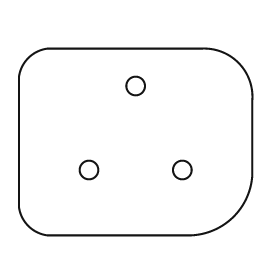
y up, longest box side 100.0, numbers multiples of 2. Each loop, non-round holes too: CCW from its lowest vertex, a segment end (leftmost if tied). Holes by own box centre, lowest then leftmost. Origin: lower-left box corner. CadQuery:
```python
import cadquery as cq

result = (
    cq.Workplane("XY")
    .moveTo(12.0, 0.0)
    .lineTo(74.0, 0.0)
    .threePointArc((92.0, 8.0), (100.0, 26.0))
    .lineTo(100.0, 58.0)
    .threePointArc((94.0, 74.0), (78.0, 80.0))
    .lineTo(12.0, 80.0)
    .threePointArc((4.0, 76.0), (0.0, 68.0))
    .lineTo(0.0, 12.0)
    .threePointArc((4.0, 4.0), (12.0, 0.0))
    .close()
    .moveTo(30.0, 28.0)
    .circle(4.0)
    .moveTo(70.0, 28.0)
    .circle(4.0)
    .moveTo(50.0, 64.0)
    .circle(4.0)
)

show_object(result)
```